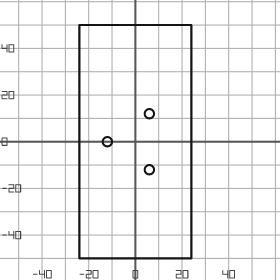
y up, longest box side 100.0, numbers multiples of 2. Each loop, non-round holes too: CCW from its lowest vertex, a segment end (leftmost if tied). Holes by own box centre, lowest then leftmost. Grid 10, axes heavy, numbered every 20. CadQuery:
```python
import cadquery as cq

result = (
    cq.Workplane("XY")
    .moveTo(-24.0, -50.0)
    .lineTo(24.0, -50.0)
    .lineTo(24.0, 50.0)
    .lineTo(-24.0, 50.0)
    .close()
    .moveTo(6.0, -12.0)
    .circle(2.0)
    .moveTo(-12.0, 0.0)
    .circle(2.0)
    .moveTo(6.0, 12.0)
    .circle(2.0)
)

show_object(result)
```